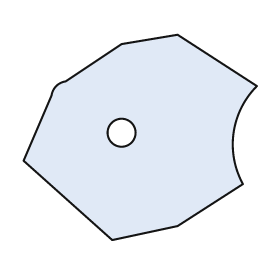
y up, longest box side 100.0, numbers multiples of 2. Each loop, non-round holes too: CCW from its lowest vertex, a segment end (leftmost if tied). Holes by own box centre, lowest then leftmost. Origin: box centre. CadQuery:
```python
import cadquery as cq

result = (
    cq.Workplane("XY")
    .moveTo(-12.0, -44.0)
    .lineTo(16.0, -38.0)
    .lineTo(44.0, -20.0)
    .threePointArc((40.0, 2.0), (50.0, 22.0))
    .lineTo(16.0, 44.0)
    .lineTo(-8.0, 40.0)
    .lineTo(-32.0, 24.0)
    .threePointArc((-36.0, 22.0), (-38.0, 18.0))
    .lineTo(-50.0, -10.0)
    .close()
    .moveTo(-8.0, 2.0)
    .circle(6.0)
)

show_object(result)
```